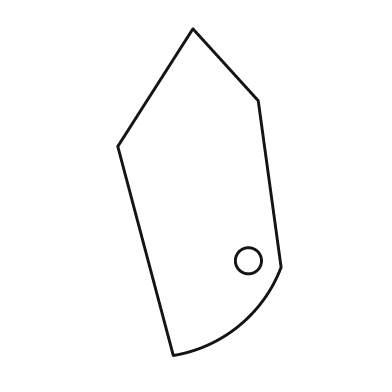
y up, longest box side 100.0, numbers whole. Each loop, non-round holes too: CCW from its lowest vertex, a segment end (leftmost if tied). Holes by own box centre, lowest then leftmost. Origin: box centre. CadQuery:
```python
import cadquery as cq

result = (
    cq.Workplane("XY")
    .moveTo(-8.0, -50.0)
    .threePointArc((12.0, -41.0), (25.0, -23.0))
    .lineTo(18.0, 28.0)
    .lineTo(-2.0, 50.0)
    .lineTo(-25.0, 14.0)
    .close()
    .moveTo(15.0, -21.0)
    .circle(4.0)
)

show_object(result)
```